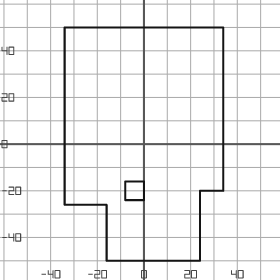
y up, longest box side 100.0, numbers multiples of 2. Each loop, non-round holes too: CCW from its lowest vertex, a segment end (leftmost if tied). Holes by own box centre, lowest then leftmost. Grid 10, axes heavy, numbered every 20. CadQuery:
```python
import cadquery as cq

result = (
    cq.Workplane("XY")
    .moveTo(-16.0, -50.0)
    .lineTo(24.0, -50.0)
    .lineTo(24.0, -20.0)
    .lineTo(34.0, -20.0)
    .lineTo(34.0, 50.0)
    .lineTo(-34.0, 50.0)
    .lineTo(-34.0, -26.0)
    .lineTo(-16.0, -26.0)
    .close()
    .moveTo(-8.0, -24.0)
    .lineTo(0.0, -24.0)
    .lineTo(0.0, -16.0)
    .lineTo(-8.0, -16.0)
    .close()
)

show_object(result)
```